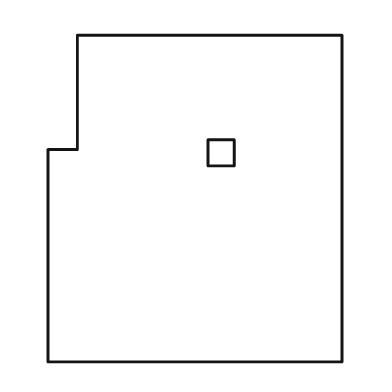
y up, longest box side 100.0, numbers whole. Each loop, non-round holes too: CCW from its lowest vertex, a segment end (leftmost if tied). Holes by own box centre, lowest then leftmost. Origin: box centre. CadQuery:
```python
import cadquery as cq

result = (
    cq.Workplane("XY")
    .moveTo(-45.0, -50.0)
    .lineTo(45.0, -50.0)
    .lineTo(45.0, 50.0)
    .lineTo(-36.0, 50.0)
    .lineTo(-36.0, 15.0)
    .lineTo(-45.0, 15.0)
    .close()
    .moveTo(4.0, 10.0)
    .lineTo(12.0, 10.0)
    .lineTo(12.0, 18.0)
    .lineTo(4.0, 18.0)
    .close()
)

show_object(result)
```